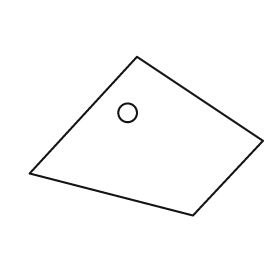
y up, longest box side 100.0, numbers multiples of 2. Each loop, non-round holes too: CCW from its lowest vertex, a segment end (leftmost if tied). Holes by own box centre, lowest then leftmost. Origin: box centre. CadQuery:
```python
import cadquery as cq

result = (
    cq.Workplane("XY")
    .moveTo(20.0, -34.0)
    .lineTo(50.0, -2.0)
    .lineTo(-4.0, 34.0)
    .lineTo(-50.0, -16.0)
    .close()
    .moveTo(-8.0, 10.0)
    .circle(4.0)
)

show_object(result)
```